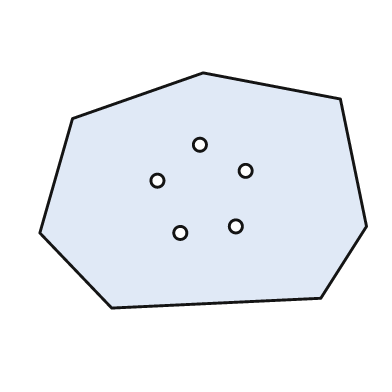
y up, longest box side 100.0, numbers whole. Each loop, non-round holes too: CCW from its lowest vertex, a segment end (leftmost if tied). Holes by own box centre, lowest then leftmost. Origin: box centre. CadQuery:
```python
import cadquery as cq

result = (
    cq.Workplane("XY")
    .moveTo(-28.0, -36.0)
    .lineTo(36.0, -33.0)
    .lineTo(50.0, -11.0)
    .lineTo(42.0, 28.0)
    .lineTo(0.0, 36.0)
    .lineTo(-40.0, 22.0)
    .lineTo(-50.0, -13.0)
    .close()
    .moveTo(-7.0, -13.0)
    .circle(2.0)
    .moveTo(10.0, -11.0)
    .circle(2.0)
    .moveTo(-14.0, 3.0)
    .circle(2.0)
    .moveTo(13.0, 6.0)
    .circle(2.0)
    .moveTo(-1.0, 14.0)
    .circle(2.0)
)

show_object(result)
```